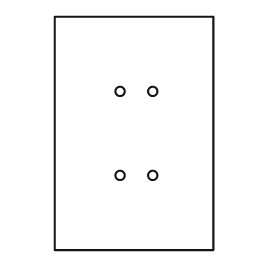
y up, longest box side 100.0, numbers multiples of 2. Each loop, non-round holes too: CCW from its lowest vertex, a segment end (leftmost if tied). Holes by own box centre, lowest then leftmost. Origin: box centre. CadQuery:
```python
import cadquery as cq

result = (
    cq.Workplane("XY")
    .moveTo(-34.0, -50.0)
    .lineTo(34.0, -50.0)
    .lineTo(34.0, 50.0)
    .lineTo(-34.0, 50.0)
    .close()
    .moveTo(-6.0, -18.0)
    .circle(2.0)
    .moveTo(8.0, -18.0)
    .circle(2.0)
    .moveTo(-6.0, 18.0)
    .circle(2.0)
    .moveTo(8.0, 18.0)
    .circle(2.0)
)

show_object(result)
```